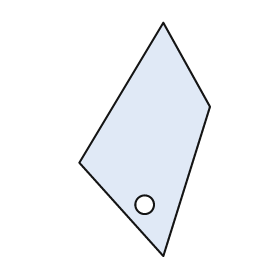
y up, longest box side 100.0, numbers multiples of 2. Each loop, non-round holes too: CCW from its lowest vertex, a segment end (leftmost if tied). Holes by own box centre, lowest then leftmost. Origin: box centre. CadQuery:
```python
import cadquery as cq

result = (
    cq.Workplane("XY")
    .moveTo(8.0, -50.0)
    .lineTo(28.0, 14.0)
    .lineTo(8.0, 50.0)
    .lineTo(-28.0, -10.0)
    .close()
    .moveTo(0.0, -28.0)
    .circle(4.0)
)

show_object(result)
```